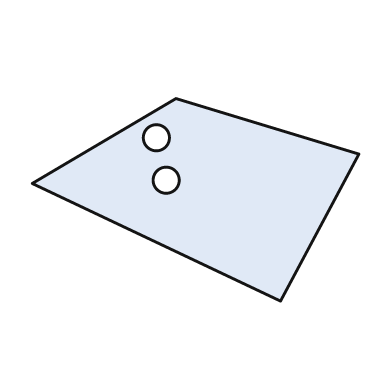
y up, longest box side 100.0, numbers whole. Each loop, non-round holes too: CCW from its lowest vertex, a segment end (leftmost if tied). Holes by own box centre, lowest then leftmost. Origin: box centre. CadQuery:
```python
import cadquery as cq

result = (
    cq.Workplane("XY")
    .moveTo(26.0, -31.0)
    .lineTo(50.0, 14.0)
    .lineTo(-6.0, 31.0)
    .lineTo(-50.0, 5.0)
    .close()
    .moveTo(-9.0, 6.0)
    .circle(4.0)
    .moveTo(-12.0, 19.0)
    .circle(4.0)
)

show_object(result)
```